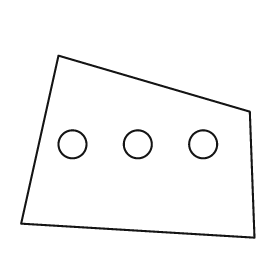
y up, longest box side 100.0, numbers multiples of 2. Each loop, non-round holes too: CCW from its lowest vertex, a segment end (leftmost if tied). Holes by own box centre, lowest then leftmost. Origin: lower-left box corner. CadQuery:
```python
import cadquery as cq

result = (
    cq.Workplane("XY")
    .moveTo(100.0, 0.0)
    .lineTo(98.0, 54.0)
    .lineTo(16.0, 78.0)
    .lineTo(0.0, 6.0)
    .close()
    .moveTo(22.0, 40.0)
    .circle(6.0)
    .moveTo(50.0, 40.0)
    .circle(6.0)
    .moveTo(78.0, 40.0)
    .circle(6.0)
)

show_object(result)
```